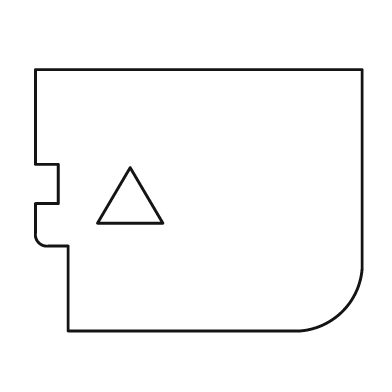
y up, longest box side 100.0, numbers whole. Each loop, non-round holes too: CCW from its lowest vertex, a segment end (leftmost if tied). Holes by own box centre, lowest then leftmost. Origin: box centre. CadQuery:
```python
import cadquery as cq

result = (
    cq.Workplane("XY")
    .moveTo(-40.0, -40.0)
    .lineTo(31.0, -40.0)
    .threePointArc((44.0, -34.0), (50.0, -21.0))
    .lineTo(50.0, 40.0)
    .lineTo(-50.0, 40.0)
    .lineTo(-50.0, 11.0)
    .lineTo(-43.0, 11.0)
    .lineTo(-43.0, -1.0)
    .lineTo(-50.0, -1.0)
    .lineTo(-50.0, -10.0)
    .threePointArc((-49.0, -13.0), (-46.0, -14.0))
    .lineTo(-40.0, -14.0)
    .close()
    .moveTo(-31.0, -7.0)
    .lineTo(-11.0, -7.0)
    .lineTo(-21.0, 10.0)
    .close()
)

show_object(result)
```